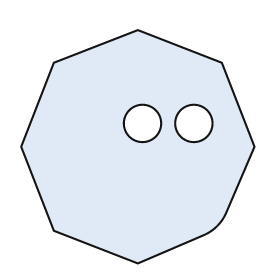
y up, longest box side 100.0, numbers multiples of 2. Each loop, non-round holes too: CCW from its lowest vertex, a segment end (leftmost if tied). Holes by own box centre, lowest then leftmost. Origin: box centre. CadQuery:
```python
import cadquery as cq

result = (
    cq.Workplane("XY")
    .moveTo(0.0, -50.0)
    .lineTo(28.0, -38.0)
    .threePointArc((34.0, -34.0), (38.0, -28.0))
    .lineTo(50.0, 0.0)
    .lineTo(36.0, 36.0)
    .lineTo(0.0, 50.0)
    .lineTo(-36.0, 36.0)
    .lineTo(-50.0, 0.0)
    .lineTo(-36.0, -36.0)
    .close()
    .moveTo(2.0, 10.0)
    .circle(8.0)
    .moveTo(24.0, 10.0)
    .circle(8.0)
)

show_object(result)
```